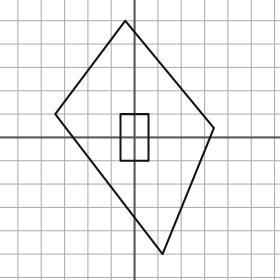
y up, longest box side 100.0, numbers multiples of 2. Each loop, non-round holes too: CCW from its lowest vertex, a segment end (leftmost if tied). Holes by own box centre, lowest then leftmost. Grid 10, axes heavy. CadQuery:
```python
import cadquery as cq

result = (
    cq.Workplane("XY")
    .moveTo(12.0, -50.0)
    .lineTo(34.0, 4.0)
    .lineTo(-4.0, 50.0)
    .lineTo(-34.0, 10.0)
    .close()
    .moveTo(-6.0, -10.0)
    .lineTo(6.0, -10.0)
    .lineTo(6.0, 10.0)
    .lineTo(-6.0, 10.0)
    .close()
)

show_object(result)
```